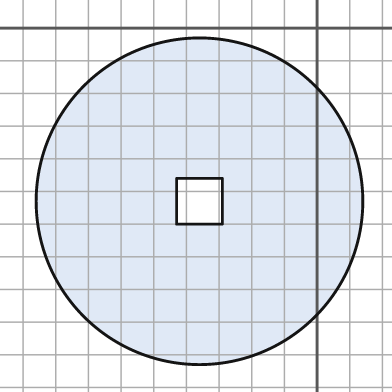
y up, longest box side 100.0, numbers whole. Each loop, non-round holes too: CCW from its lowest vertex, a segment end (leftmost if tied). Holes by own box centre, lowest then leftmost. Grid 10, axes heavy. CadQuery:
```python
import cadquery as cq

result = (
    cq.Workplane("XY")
    .moveTo(-36.0, -53.0)
    .circle(50.0)
    .moveTo(-43.0, -60.0)
    .lineTo(-29.0, -60.0)
    .lineTo(-29.0, -46.0)
    .lineTo(-43.0, -46.0)
    .close()
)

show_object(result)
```